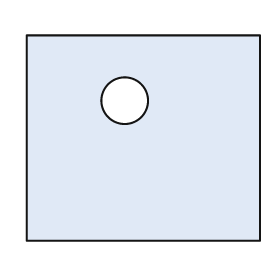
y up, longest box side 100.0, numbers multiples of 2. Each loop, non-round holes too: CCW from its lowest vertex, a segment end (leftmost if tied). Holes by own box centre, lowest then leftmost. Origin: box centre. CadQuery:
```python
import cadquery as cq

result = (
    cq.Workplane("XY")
    .moveTo(-50.0, -44.0)
    .lineTo(50.0, -44.0)
    .lineTo(50.0, 44.0)
    .lineTo(-50.0, 44.0)
    .close()
    .moveTo(-8.0, 16.0)
    .circle(10.0)
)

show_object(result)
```